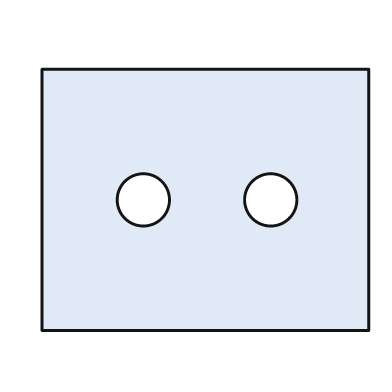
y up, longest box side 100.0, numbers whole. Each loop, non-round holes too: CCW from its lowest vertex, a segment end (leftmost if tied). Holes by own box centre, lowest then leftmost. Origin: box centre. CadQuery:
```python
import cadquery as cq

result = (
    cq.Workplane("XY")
    .moveTo(-50.0, -40.0)
    .lineTo(50.0, -40.0)
    .lineTo(50.0, 40.0)
    .lineTo(-50.0, 40.0)
    .close()
    .moveTo(-19.0, 0.0)
    .circle(8.0)
    .moveTo(20.0, 0.0)
    .circle(8.0)
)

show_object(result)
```